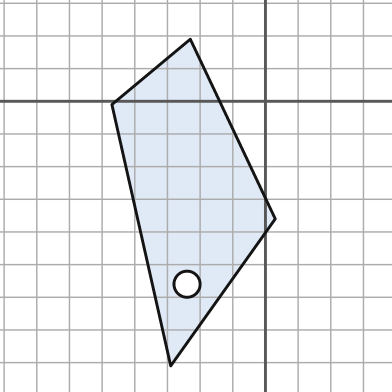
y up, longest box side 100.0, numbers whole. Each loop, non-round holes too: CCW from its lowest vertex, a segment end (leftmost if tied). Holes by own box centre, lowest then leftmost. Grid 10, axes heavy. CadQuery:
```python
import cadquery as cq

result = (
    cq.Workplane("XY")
    .moveTo(-29.0, -81.0)
    .lineTo(3.0, -36.0)
    .lineTo(-23.0, 19.0)
    .lineTo(-47.0, -1.0)
    .close()
    .moveTo(-24.0, -56.0)
    .circle(4.0)
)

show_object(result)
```